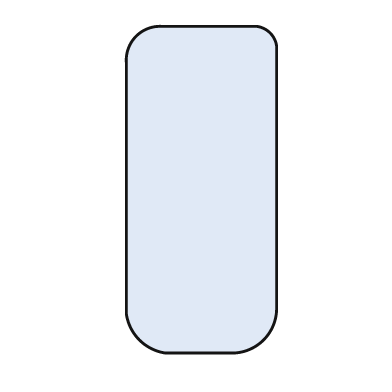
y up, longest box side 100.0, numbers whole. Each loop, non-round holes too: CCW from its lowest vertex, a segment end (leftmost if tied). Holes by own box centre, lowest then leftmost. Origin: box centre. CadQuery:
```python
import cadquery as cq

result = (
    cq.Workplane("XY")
    .moveTo(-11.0, -50.0)
    .lineTo(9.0, -50.0)
    .threePointArc((19.0, -46.0), (23.0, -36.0))
    .lineTo(23.0, 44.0)
    .threePointArc((21.0, 48.0), (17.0, 50.0))
    .lineTo(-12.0, 50.0)
    .threePointArc((-20.0, 47.0), (-23.0, 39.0))
    .lineTo(-23.0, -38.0)
    .threePointArc((-19.0, -46.0), (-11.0, -50.0))
    .close()
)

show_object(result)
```